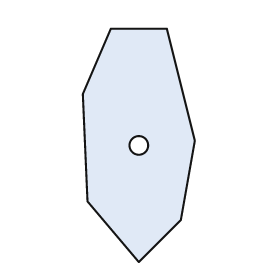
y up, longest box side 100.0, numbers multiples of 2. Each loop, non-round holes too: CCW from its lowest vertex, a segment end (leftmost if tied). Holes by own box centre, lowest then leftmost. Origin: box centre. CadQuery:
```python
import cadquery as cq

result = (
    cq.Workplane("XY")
    .moveTo(0.0, -50.0)
    .lineTo(18.0, -32.0)
    .lineTo(24.0, 2.0)
    .lineTo(12.0, 50.0)
    .lineTo(-12.0, 50.0)
    .lineTo(-24.0, 22.0)
    .lineTo(-22.0, -24.0)
    .close()
    .moveTo(0.0, 0.0)
    .circle(4.0)
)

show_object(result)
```